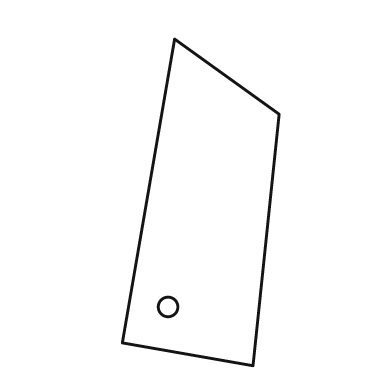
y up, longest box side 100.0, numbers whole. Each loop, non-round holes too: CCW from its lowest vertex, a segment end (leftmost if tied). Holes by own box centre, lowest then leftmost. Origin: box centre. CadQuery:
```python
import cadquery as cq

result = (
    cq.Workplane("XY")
    .moveTo(16.0, -50.0)
    .lineTo(24.0, 27.0)
    .lineTo(-8.0, 50.0)
    .lineTo(-24.0, -43.0)
    .close()
    .moveTo(-10.0, -32.0)
    .circle(3.0)
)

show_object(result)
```